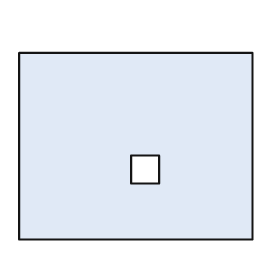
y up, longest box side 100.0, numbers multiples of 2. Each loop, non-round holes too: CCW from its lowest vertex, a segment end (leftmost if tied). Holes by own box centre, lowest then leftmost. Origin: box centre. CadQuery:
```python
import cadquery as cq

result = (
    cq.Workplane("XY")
    .moveTo(-50.0, -40.0)
    .lineTo(50.0, -40.0)
    .lineTo(50.0, 40.0)
    .lineTo(-50.0, 40.0)
    .close()
    .moveTo(-2.0, -16.0)
    .lineTo(10.0, -16.0)
    .lineTo(10.0, -4.0)
    .lineTo(-2.0, -4.0)
    .close()
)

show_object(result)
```